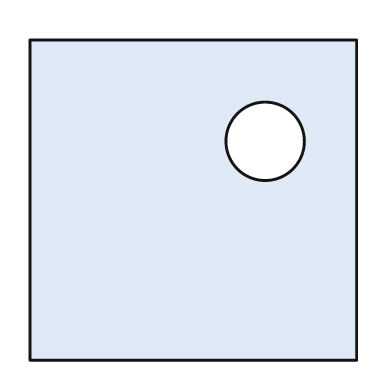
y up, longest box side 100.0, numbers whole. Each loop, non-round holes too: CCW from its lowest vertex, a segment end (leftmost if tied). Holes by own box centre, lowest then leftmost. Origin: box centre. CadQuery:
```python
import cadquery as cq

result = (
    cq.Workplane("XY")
    .moveTo(-50.0, -49.0)
    .lineTo(50.0, -49.0)
    .lineTo(50.0, 49.0)
    .lineTo(-50.0, 49.0)
    .close()
    .moveTo(22.0, 18.0)
    .circle(12.0)
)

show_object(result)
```